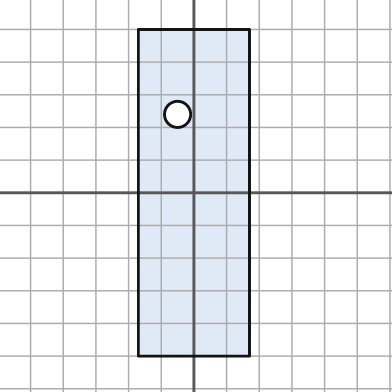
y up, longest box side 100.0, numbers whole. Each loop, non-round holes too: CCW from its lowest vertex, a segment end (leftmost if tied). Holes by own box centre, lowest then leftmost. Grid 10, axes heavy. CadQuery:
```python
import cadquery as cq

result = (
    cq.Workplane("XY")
    .moveTo(-17.0, -50.0)
    .lineTo(17.0, -50.0)
    .lineTo(17.0, 50.0)
    .lineTo(-17.0, 50.0)
    .close()
    .moveTo(-5.0, 24.0)
    .circle(4.0)
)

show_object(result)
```